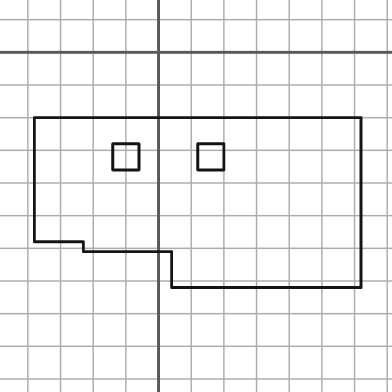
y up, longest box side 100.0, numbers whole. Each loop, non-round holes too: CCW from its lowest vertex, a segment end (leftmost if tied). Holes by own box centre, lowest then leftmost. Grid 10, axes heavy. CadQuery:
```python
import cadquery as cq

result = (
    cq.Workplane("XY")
    .moveTo(4.0, -72.0)
    .lineTo(62.0, -72.0)
    .lineTo(62.0, -20.0)
    .lineTo(-38.0, -20.0)
    .lineTo(-38.0, -58.0)
    .lineTo(-23.0, -58.0)
    .lineTo(-23.0, -61.0)
    .lineTo(4.0, -61.0)
    .close()
    .moveTo(-14.0, -36.0)
    .lineTo(-6.0, -36.0)
    .lineTo(-6.0, -28.0)
    .lineTo(-14.0, -28.0)
    .close()
    .moveTo(12.0, -36.0)
    .lineTo(20.0, -36.0)
    .lineTo(20.0, -28.0)
    .lineTo(12.0, -28.0)
    .close()
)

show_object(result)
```